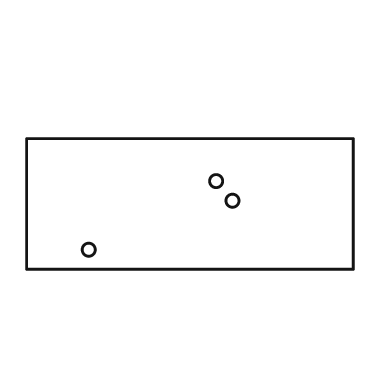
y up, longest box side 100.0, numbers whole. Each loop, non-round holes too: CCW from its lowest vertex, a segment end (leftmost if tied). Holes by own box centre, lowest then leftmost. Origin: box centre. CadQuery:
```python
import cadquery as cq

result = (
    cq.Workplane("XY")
    .moveTo(-50.0, -20.0)
    .lineTo(50.0, -20.0)
    .lineTo(50.0, 20.0)
    .lineTo(-50.0, 20.0)
    .close()
    .moveTo(-31.0, -14.0)
    .circle(2.0)
    .moveTo(13.0, 1.0)
    .circle(2.0)
    .moveTo(8.0, 7.0)
    .circle(2.0)
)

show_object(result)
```